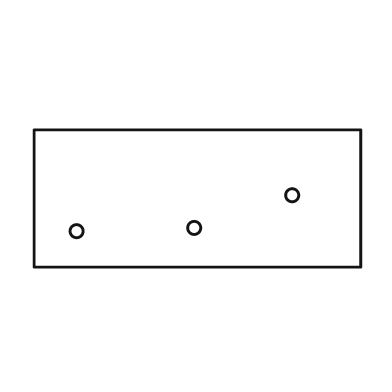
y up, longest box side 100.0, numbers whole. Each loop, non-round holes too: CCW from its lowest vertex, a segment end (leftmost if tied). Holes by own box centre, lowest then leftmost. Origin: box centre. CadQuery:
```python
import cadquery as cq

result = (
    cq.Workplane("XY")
    .moveTo(-50.0, -21.0)
    .lineTo(50.0, -21.0)
    .lineTo(50.0, 21.0)
    .lineTo(-50.0, 21.0)
    .close()
    .moveTo(-37.0, -10.0)
    .circle(2.0)
    .moveTo(-1.0, -9.0)
    .circle(2.0)
    .moveTo(29.0, 1.0)
    .circle(2.0)
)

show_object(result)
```